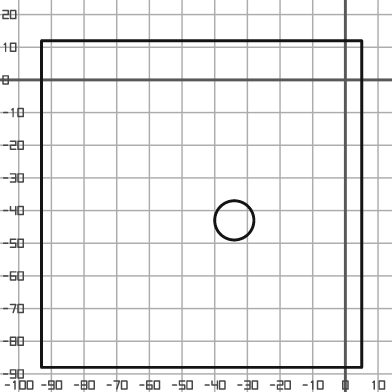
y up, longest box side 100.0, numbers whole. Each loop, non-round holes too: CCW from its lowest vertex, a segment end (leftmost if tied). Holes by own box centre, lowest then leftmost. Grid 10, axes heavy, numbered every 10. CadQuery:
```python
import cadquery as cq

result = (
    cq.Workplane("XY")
    .moveTo(-93.0, -88.0)
    .lineTo(5.0, -88.0)
    .lineTo(5.0, 12.0)
    .lineTo(-93.0, 12.0)
    .close()
    .moveTo(-34.0, -43.0)
    .circle(6.0)
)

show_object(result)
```